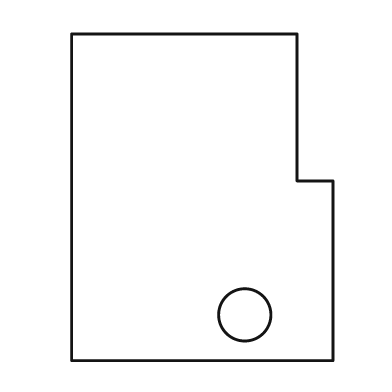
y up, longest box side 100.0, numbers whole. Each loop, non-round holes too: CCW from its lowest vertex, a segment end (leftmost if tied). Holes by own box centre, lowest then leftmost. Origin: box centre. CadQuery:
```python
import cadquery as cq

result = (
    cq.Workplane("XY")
    .moveTo(-40.0, -50.0)
    .lineTo(40.0, -50.0)
    .lineTo(40.0, 5.0)
    .lineTo(29.0, 5.0)
    .lineTo(29.0, 50.0)
    .lineTo(-40.0, 50.0)
    .close()
    .moveTo(13.0, -36.0)
    .circle(8.0)
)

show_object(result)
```